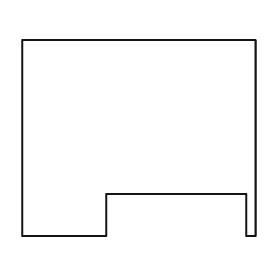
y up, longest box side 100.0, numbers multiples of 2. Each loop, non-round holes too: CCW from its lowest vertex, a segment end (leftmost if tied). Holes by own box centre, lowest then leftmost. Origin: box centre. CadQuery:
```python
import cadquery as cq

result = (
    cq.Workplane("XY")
    .moveTo(-50.0, -42.0)
    .lineTo(-14.0, -42.0)
    .lineTo(-14.0, -24.0)
    .lineTo(46.0, -24.0)
    .lineTo(46.0, -42.0)
    .lineTo(50.0, -42.0)
    .lineTo(50.0, 42.0)
    .lineTo(-50.0, 42.0)
    .close()
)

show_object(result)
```